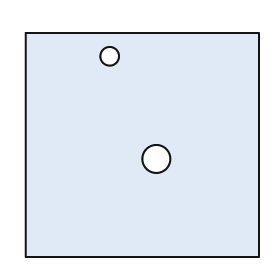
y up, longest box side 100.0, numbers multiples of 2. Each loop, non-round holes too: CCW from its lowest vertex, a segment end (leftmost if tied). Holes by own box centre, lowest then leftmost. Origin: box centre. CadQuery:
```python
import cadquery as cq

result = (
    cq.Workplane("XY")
    .moveTo(-50.0, -48.0)
    .lineTo(50.0, -48.0)
    .lineTo(50.0, 48.0)
    .lineTo(-50.0, 48.0)
    .close()
    .moveTo(6.0, -6.0)
    .circle(6.0)
    .moveTo(-14.0, 38.0)
    .circle(4.0)
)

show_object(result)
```